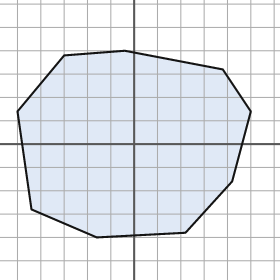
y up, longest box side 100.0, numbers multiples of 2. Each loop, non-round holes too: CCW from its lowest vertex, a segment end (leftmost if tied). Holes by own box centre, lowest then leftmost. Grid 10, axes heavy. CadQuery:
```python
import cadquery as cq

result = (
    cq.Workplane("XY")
    .moveTo(-16.0, -40.0)
    .lineTo(22.0, -38.0)
    .lineTo(42.0, -16.0)
    .lineTo(50.0, 14.0)
    .lineTo(38.0, 32.0)
    .lineTo(-4.0, 40.0)
    .lineTo(-30.0, 38.0)
    .lineTo(-50.0, 14.0)
    .lineTo(-44.0, -28.0)
    .close()
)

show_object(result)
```